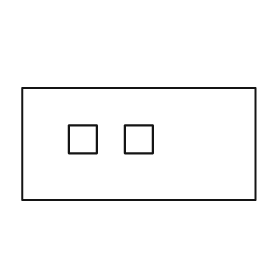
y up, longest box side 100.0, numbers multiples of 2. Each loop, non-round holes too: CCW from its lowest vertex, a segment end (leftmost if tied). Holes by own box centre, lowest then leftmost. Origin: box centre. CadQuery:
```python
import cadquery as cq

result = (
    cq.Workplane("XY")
    .moveTo(-50.0, -24.0)
    .lineTo(50.0, -24.0)
    .lineTo(50.0, 24.0)
    .lineTo(-50.0, 24.0)
    .close()
    .moveTo(-30.0, -4.0)
    .lineTo(-18.0, -4.0)
    .lineTo(-18.0, 8.0)
    .lineTo(-30.0, 8.0)
    .close()
    .moveTo(-6.0, -4.0)
    .lineTo(6.0, -4.0)
    .lineTo(6.0, 8.0)
    .lineTo(-6.0, 8.0)
    .close()
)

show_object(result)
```